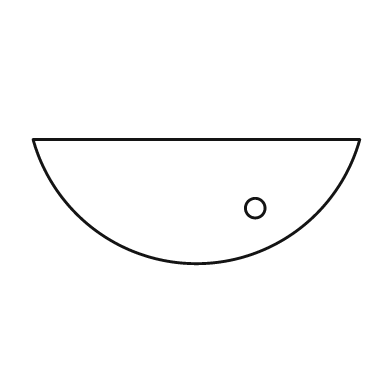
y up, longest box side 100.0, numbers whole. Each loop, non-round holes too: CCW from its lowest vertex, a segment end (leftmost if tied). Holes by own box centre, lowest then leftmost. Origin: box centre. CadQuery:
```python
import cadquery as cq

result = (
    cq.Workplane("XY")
    .moveTo(-50.0, 19.0)
    .threePointArc((0.0, -19.0), (50.0, 19.0))
    .close()
    .moveTo(18.0, -2.0)
    .circle(3.0)
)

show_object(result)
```